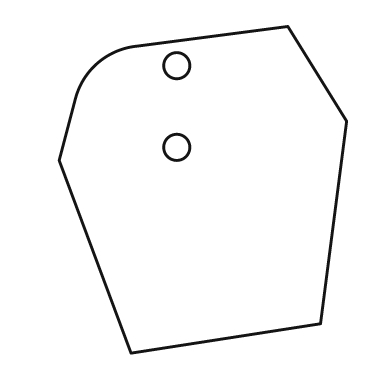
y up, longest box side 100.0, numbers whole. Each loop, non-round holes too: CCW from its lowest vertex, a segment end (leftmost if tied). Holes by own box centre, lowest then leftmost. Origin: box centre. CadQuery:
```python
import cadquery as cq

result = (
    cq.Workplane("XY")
    .moveTo(-22.0, -50.0)
    .lineTo(36.0, -41.0)
    .lineTo(44.0, 21.0)
    .lineTo(26.0, 50.0)
    .lineTo(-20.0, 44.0)
    .threePointArc((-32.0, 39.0), (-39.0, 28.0))
    .lineTo(-44.0, 9.0)
    .close()
    .moveTo(-8.0, 13.0)
    .circle(4.0)
    .moveTo(-8.0, 38.0)
    .circle(4.0)
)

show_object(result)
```